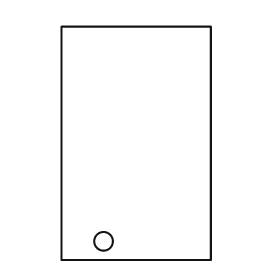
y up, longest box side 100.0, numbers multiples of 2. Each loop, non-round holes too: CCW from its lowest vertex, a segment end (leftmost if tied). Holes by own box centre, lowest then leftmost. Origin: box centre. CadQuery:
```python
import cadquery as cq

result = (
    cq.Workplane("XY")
    .moveTo(-32.0, -50.0)
    .lineTo(32.0, -50.0)
    .lineTo(32.0, 50.0)
    .lineTo(-32.0, 50.0)
    .close()
    .moveTo(-14.0, -42.0)
    .circle(4.0)
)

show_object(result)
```